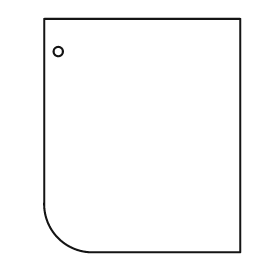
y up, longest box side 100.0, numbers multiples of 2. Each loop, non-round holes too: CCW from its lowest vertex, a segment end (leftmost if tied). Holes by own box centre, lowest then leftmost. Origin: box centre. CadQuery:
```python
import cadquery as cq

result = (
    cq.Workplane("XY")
    .moveTo(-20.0, -50.0)
    .lineTo(42.0, -50.0)
    .lineTo(42.0, 50.0)
    .lineTo(-42.0, 50.0)
    .lineTo(-42.0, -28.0)
    .threePointArc((-36.0, -44.0), (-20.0, -50.0))
    .close()
    .moveTo(-36.0, 36.0)
    .circle(2.0)
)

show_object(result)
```